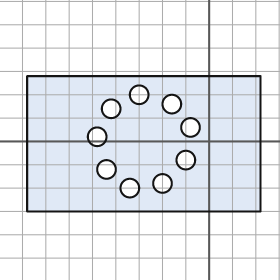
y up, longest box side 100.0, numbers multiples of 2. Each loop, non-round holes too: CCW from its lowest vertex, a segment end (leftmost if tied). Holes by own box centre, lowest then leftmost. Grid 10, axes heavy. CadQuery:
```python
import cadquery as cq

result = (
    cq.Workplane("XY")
    .moveTo(-78.0, -30.0)
    .lineTo(22.0, -30.0)
    .lineTo(22.0, 28.0)
    .lineTo(-78.0, 28.0)
    .close()
    .moveTo(-34.0, -20.0)
    .circle(4.0)
    .moveTo(-20.0, -18.0)
    .circle(4.0)
    .moveTo(-44.0, -12.0)
    .circle(4.0)
    .moveTo(-10.0, -8.0)
    .circle(4.0)
    .moveTo(-48.0, 2.0)
    .circle(4.0)
    .moveTo(-8.0, 6.0)
    .circle(4.0)
    .moveTo(-42.0, 14.0)
    .circle(4.0)
    .moveTo(-16.0, 16.0)
    .circle(4.0)
    .moveTo(-30.0, 20.0)
    .circle(4.0)
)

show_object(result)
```